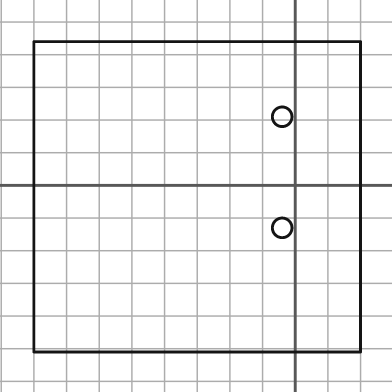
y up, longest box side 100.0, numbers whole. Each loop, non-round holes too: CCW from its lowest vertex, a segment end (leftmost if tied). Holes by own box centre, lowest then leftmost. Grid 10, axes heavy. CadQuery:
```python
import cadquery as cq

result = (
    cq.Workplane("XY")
    .moveTo(-80.0, -51.0)
    .lineTo(20.0, -51.0)
    .lineTo(20.0, 44.0)
    .lineTo(-80.0, 44.0)
    .close()
    .moveTo(-4.0, -13.0)
    .circle(3.0)
    .moveTo(-4.0, 21.0)
    .circle(3.0)
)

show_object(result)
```